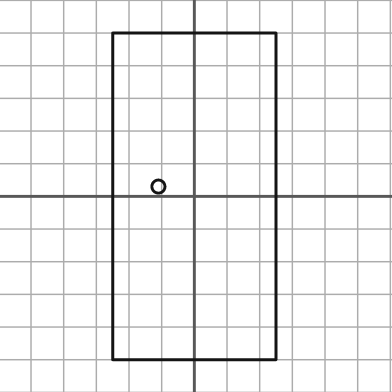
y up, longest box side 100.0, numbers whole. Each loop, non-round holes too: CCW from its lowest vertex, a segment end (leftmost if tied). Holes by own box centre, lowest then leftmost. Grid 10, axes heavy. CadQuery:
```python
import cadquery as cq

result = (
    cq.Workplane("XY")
    .moveTo(-25.0, -50.0)
    .lineTo(25.0, -50.0)
    .lineTo(25.0, 50.0)
    .lineTo(-25.0, 50.0)
    .close()
    .moveTo(-11.0, 3.0)
    .circle(2.0)
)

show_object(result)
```